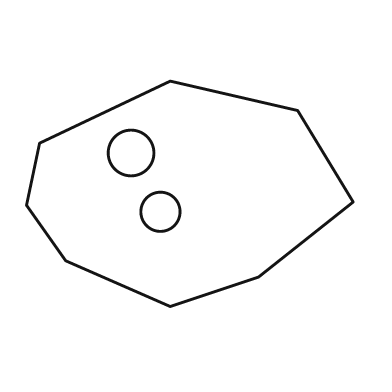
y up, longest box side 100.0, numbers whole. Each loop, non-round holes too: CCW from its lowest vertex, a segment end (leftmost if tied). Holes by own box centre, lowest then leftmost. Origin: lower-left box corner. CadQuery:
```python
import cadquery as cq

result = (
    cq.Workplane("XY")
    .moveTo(44.0, 0.0)
    .lineTo(71.0, 9.0)
    .lineTo(100.0, 32.0)
    .lineTo(83.0, 60.0)
    .lineTo(44.0, 69.0)
    .lineTo(4.0, 50.0)
    .lineTo(0.0, 31.0)
    .lineTo(12.0, 14.0)
    .close()
    .moveTo(41.0, 29.0)
    .circle(6.0)
    .moveTo(32.0, 47.0)
    .circle(7.0)
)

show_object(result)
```